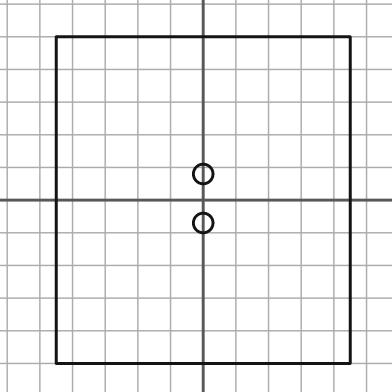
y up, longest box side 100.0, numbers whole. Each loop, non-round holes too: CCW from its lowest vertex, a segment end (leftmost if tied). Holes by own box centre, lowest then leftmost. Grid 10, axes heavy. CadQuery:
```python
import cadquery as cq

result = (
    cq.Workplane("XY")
    .moveTo(-45.0, -50.0)
    .lineTo(45.0, -50.0)
    .lineTo(45.0, 50.0)
    .lineTo(-45.0, 50.0)
    .close()
    .moveTo(0.0, -7.0)
    .circle(3.0)
    .moveTo(0.0, 8.0)
    .circle(3.0)
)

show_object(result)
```